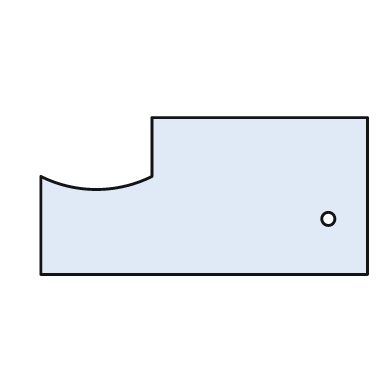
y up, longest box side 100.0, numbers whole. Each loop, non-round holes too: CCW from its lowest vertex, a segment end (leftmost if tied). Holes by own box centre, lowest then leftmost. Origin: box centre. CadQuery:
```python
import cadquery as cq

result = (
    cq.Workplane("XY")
    .moveTo(-50.0, -24.0)
    .lineTo(50.0, -24.0)
    .lineTo(50.0, 24.0)
    .lineTo(-16.0, 24.0)
    .lineTo(-16.0, 6.0)
    .threePointArc((-33.0, 2.0), (-50.0, 6.0))
    .close()
    .moveTo(38.0, -7.0)
    .circle(2.0)
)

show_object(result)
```